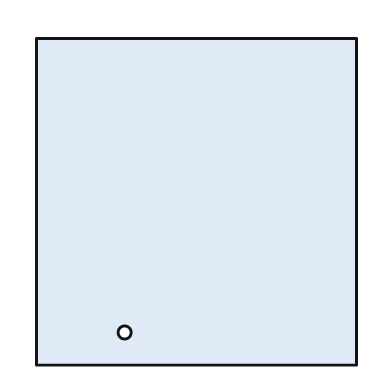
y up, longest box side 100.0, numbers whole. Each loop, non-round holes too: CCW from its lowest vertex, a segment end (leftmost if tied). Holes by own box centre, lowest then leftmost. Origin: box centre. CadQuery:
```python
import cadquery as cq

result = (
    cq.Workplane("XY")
    .moveTo(-49.0, -50.0)
    .lineTo(49.0, -50.0)
    .lineTo(49.0, 50.0)
    .lineTo(-49.0, 50.0)
    .close()
    .moveTo(-22.0, -40.0)
    .circle(2.0)
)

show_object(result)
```